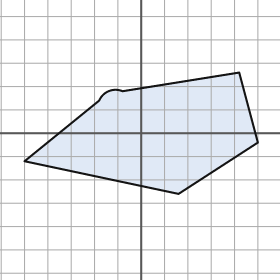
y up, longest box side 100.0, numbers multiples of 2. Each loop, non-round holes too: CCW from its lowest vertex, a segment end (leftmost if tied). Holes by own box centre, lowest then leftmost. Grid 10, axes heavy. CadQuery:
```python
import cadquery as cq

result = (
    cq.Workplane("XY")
    .moveTo(16.0, -26.0)
    .lineTo(50.0, -4.0)
    .lineTo(42.0, 26.0)
    .lineTo(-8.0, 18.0)
    .threePointArc((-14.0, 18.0), (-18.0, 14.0))
    .lineTo(-50.0, -12.0)
    .close()
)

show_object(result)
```